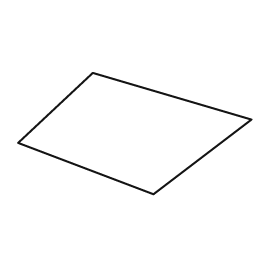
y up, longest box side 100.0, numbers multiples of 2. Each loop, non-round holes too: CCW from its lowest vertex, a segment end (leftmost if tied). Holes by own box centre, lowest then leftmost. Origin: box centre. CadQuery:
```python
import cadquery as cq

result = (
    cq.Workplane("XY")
    .moveTo(8.0, -26.0)
    .lineTo(50.0, 6.0)
    .lineTo(-18.0, 26.0)
    .lineTo(-50.0, -4.0)
    .close()
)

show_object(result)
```